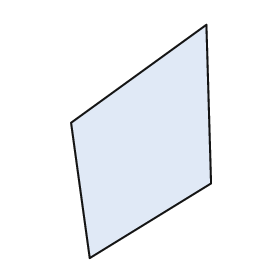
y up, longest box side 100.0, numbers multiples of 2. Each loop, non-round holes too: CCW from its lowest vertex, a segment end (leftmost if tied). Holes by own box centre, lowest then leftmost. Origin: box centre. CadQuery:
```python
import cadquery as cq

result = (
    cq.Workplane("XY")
    .moveTo(-22.0, -50.0)
    .lineTo(30.0, -18.0)
    .lineTo(28.0, 50.0)
    .lineTo(-30.0, 8.0)
    .close()
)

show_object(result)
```